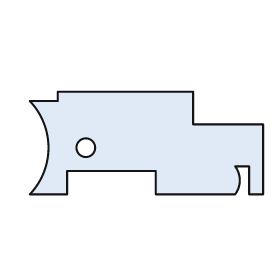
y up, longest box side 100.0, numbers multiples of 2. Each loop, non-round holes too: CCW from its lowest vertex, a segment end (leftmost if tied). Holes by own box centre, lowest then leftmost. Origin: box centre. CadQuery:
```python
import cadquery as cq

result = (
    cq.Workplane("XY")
    .moveTo(-50.0, -22.0)
    .lineTo(-34.0, -22.0)
    .lineTo(-34.0, -12.0)
    .lineTo(4.0, -12.0)
    .lineTo(4.0, -22.0)
    .lineTo(38.0, -22.0)
    .threePointArc((40.0, -16.0), (38.0, -10.0))
    .lineTo(44.0, -10.0)
    .lineTo(44.0, -22.0)
    .lineTo(50.0, -22.0)
    .lineTo(50.0, 8.0)
    .lineTo(20.0, 8.0)
    .lineTo(20.0, 22.0)
    .lineTo(-38.0, 22.0)
    .lineTo(-38.0, 18.0)
    .lineTo(-50.0, 18.0)
    .threePointArc((-42.0, -2.0), (-50.0, -22.0))
    .close()
    .moveTo(-26.0, -2.0)
    .circle(4.0)
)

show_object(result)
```